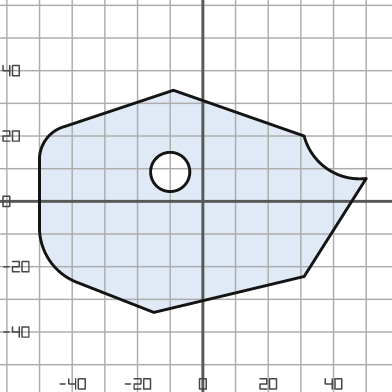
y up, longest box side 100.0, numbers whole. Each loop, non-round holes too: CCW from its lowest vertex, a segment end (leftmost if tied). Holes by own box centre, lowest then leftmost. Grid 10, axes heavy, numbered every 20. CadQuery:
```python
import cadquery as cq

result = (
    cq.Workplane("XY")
    .moveTo(-15.0, -34.0)
    .lineTo(31.0, -23.0)
    .lineTo(50.0, 7.0)
    .threePointArc((38.0, 10.0), (31.0, 20.0))
    .lineTo(-9.0, 34.0)
    .lineTo(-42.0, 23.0)
    .threePointArc((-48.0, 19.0), (-50.0, 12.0))
    .lineTo(-50.0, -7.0)
    .threePointArc((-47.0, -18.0), (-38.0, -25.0))
    .close()
    .moveTo(-10.0, 9.0)
    .circle(6.0)
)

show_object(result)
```